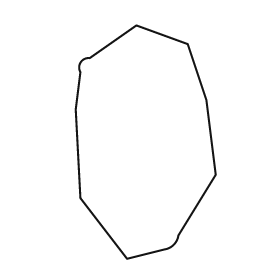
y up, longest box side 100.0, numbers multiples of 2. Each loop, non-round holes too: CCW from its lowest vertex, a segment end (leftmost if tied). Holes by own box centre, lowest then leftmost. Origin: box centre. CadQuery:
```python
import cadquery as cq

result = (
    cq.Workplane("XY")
    .moveTo(-8.0, -50.0)
    .lineTo(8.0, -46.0)
    .threePointArc((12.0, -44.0), (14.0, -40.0))
    .lineTo(30.0, -14.0)
    .lineTo(26.0, 18.0)
    .lineTo(18.0, 42.0)
    .lineTo(-4.0, 50.0)
    .lineTo(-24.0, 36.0)
    .threePointArc((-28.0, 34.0), (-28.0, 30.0))
    .lineTo(-30.0, 14.0)
    .lineTo(-28.0, -24.0)
    .close()
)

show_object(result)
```